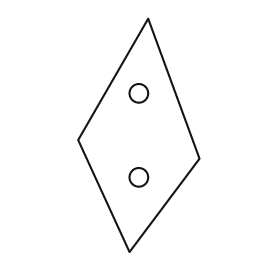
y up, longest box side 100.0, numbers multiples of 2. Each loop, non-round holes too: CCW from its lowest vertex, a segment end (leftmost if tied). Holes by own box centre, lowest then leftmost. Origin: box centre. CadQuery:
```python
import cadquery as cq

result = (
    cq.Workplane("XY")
    .moveTo(-4.0, -50.0)
    .lineTo(26.0, -10.0)
    .lineTo(4.0, 50.0)
    .lineTo(-26.0, -2.0)
    .close()
    .moveTo(0.0, -18.0)
    .circle(4.0)
    .moveTo(0.0, 18.0)
    .circle(4.0)
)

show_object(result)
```